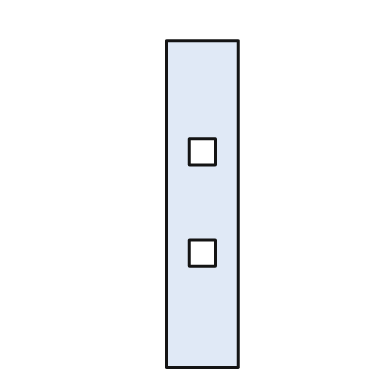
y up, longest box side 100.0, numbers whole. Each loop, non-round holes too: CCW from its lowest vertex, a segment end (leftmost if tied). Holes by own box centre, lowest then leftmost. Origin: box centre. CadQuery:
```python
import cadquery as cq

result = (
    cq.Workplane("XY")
    .moveTo(-11.0, -50.0)
    .lineTo(11.0, -50.0)
    .lineTo(11.0, 50.0)
    .lineTo(-11.0, 50.0)
    .close()
    .moveTo(-4.0, -19.0)
    .lineTo(4.0, -19.0)
    .lineTo(4.0, -11.0)
    .lineTo(-4.0, -11.0)
    .close()
    .moveTo(-4.0, 12.0)
    .lineTo(4.0, 12.0)
    .lineTo(4.0, 20.0)
    .lineTo(-4.0, 20.0)
    .close()
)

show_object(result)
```